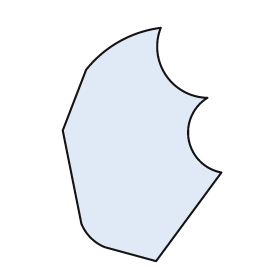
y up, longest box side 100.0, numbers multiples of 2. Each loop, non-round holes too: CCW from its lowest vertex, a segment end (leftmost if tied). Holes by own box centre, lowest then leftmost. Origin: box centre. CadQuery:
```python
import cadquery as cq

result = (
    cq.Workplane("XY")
    .moveTo(6.0, -50.0)
    .lineTo(34.0, -12.0)
    .threePointArc((20.0, 2.0), (28.0, 20.0))
    .threePointArc((10.0, 30.0), (8.0, 50.0))
    .threePointArc((-10.0, 44.0), (-24.0, 32.0))
    .lineTo(-34.0, 6.0)
    .lineTo(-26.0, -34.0)
    .threePointArc((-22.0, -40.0), (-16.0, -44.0))
    .close()
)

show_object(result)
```